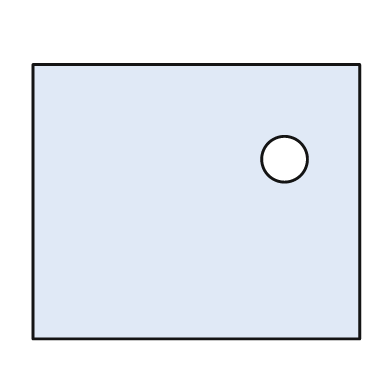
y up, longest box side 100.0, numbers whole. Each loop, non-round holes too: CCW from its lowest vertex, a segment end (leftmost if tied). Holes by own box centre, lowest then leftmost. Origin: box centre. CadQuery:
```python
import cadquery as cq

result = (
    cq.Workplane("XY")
    .moveTo(-50.0, -42.0)
    .lineTo(50.0, -42.0)
    .lineTo(50.0, 42.0)
    .lineTo(-50.0, 42.0)
    .close()
    .moveTo(27.0, 13.0)
    .circle(7.0)
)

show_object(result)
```